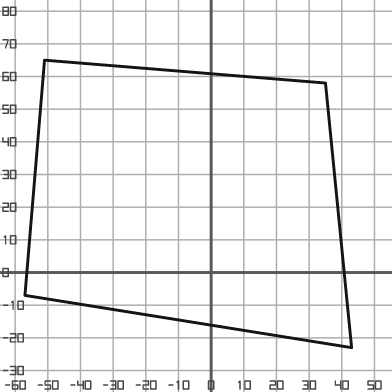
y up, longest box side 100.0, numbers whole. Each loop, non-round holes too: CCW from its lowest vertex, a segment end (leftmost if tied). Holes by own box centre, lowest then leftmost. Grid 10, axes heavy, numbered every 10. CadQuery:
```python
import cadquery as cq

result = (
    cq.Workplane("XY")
    .moveTo(43.0, -23.0)
    .lineTo(35.0, 58.0)
    .lineTo(-51.0, 65.0)
    .lineTo(-57.0, -7.0)
    .close()
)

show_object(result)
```